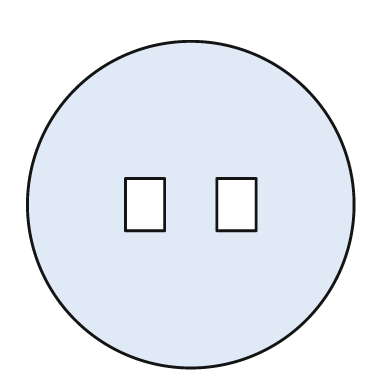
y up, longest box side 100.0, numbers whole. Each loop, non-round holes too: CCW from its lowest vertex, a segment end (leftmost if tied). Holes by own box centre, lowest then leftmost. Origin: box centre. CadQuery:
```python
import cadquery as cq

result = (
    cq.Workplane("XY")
    .moveTo(0.0, 0.0)
    .circle(50.0)
    .moveTo(-20.0, -8.0)
    .lineTo(-8.0, -8.0)
    .lineTo(-8.0, 8.0)
    .lineTo(-20.0, 8.0)
    .close()
    .moveTo(8.0, -8.0)
    .lineTo(20.0, -8.0)
    .lineTo(20.0, 8.0)
    .lineTo(8.0, 8.0)
    .close()
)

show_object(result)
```